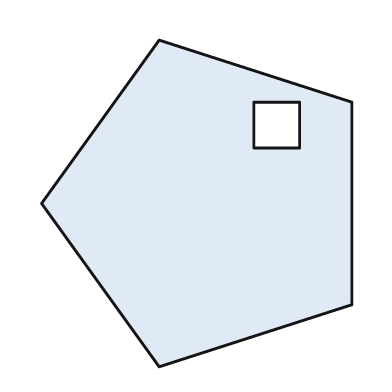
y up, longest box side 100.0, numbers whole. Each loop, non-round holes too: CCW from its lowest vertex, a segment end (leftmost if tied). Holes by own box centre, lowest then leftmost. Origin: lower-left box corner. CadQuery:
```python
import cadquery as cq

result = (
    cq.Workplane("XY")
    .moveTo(36.0, 0.0)
    .lineTo(95.0, 19.0)
    .lineTo(95.0, 81.0)
    .lineTo(36.0, 100.0)
    .lineTo(0.0, 50.0)
    .close()
    .moveTo(65.0, 67.0)
    .lineTo(79.0, 67.0)
    .lineTo(79.0, 81.0)
    .lineTo(65.0, 81.0)
    .close()
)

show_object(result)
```